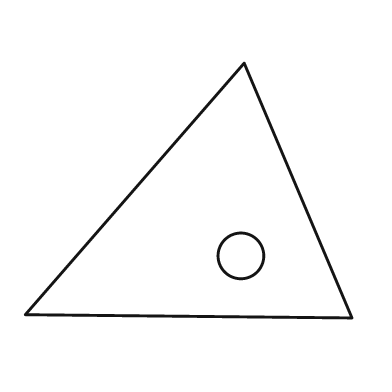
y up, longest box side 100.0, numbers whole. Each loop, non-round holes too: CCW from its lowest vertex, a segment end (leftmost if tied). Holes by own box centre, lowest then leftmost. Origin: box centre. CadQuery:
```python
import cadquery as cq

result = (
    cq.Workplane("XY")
    .moveTo(50.0, -39.0)
    .lineTo(17.0, 39.0)
    .lineTo(-50.0, -38.0)
    .close()
    .moveTo(16.0, -20.0)
    .circle(7.0)
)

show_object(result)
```